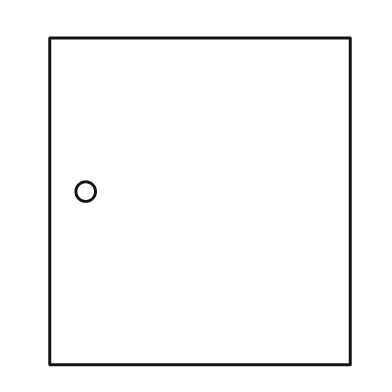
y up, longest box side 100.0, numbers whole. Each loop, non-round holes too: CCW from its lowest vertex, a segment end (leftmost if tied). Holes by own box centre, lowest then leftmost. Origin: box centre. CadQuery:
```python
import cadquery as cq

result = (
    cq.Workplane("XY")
    .moveTo(-46.0, -50.0)
    .lineTo(46.0, -50.0)
    .lineTo(46.0, 50.0)
    .lineTo(-46.0, 50.0)
    .close()
    .moveTo(-35.0, 3.0)
    .circle(3.0)
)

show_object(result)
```